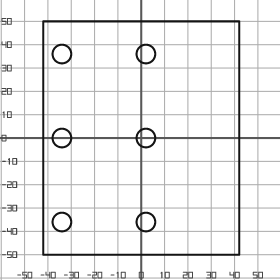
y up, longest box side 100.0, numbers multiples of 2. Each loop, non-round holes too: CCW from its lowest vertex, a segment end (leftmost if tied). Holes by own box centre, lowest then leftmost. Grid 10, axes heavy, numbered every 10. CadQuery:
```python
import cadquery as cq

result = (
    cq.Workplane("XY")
    .moveTo(-42.0, -50.0)
    .lineTo(42.0, -50.0)
    .lineTo(42.0, 50.0)
    .lineTo(-42.0, 50.0)
    .close()
    .moveTo(-34.0, -36.0)
    .circle(4.0)
    .moveTo(2.0, -36.0)
    .circle(4.0)
    .moveTo(-34.0, 0.0)
    .circle(4.0)
    .moveTo(2.0, 0.0)
    .circle(4.0)
    .moveTo(-34.0, 36.0)
    .circle(4.0)
    .moveTo(2.0, 36.0)
    .circle(4.0)
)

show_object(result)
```